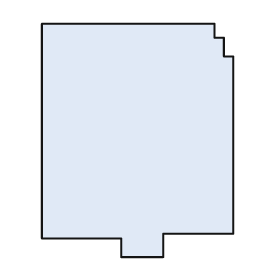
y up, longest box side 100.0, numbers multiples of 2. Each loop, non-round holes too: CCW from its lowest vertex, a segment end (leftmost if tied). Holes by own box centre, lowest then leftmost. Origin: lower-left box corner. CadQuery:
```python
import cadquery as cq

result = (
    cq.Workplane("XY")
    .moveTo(34.0, 0.0)
    .lineTo(52.0, 0.0)
    .lineTo(52.0, 10.0)
    .lineTo(82.0, 10.0)
    .lineTo(82.0, 86.0)
    .lineTo(78.0, 86.0)
    .lineTo(78.0, 94.0)
    .lineTo(74.0, 94.0)
    .lineTo(74.0, 100.0)
    .lineTo(0.0, 100.0)
    .lineTo(0.0, 8.0)
    .lineTo(34.0, 8.0)
    .close()
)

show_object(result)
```